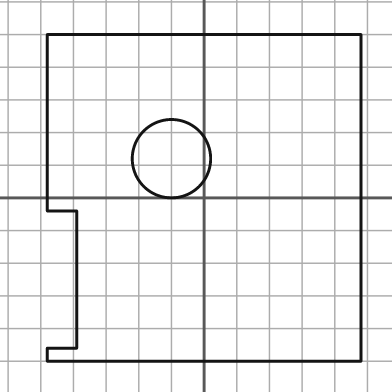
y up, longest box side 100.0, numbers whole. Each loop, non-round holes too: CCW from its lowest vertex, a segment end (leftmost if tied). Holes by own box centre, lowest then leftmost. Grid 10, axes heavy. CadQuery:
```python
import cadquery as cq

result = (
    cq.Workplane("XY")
    .moveTo(-48.0, -50.0)
    .lineTo(48.0, -50.0)
    .lineTo(48.0, 50.0)
    .lineTo(-48.0, 50.0)
    .lineTo(-48.0, -4.0)
    .lineTo(-39.0, -4.0)
    .lineTo(-39.0, -46.0)
    .lineTo(-48.0, -46.0)
    .close()
    .moveTo(-10.0, 12.0)
    .circle(12.0)
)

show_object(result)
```